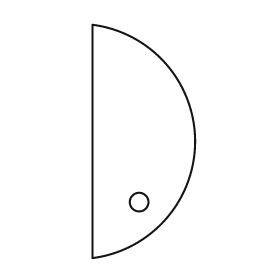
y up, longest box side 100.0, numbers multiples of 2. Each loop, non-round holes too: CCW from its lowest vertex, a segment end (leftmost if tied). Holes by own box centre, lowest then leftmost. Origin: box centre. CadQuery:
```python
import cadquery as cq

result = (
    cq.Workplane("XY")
    .moveTo(-22.0, -50.0)
    .threePointArc((22.0, 0.0), (-22.0, 50.0))
    .close()
    .moveTo(-2.0, -26.0)
    .circle(4.0)
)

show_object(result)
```